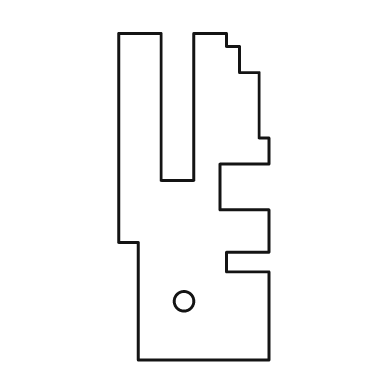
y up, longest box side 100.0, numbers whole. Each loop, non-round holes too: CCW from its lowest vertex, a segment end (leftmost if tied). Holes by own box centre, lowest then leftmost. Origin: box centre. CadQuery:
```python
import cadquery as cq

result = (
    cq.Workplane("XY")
    .moveTo(-17.0, -50.0)
    .lineTo(23.0, -50.0)
    .lineTo(23.0, -23.0)
    .lineTo(10.0, -23.0)
    .lineTo(10.0, -17.0)
    .lineTo(23.0, -17.0)
    .lineTo(23.0, -4.0)
    .lineTo(8.0, -4.0)
    .lineTo(8.0, 10.0)
    .lineTo(23.0, 10.0)
    .lineTo(23.0, 18.0)
    .lineTo(20.0, 18.0)
    .lineTo(20.0, 38.0)
    .lineTo(14.0, 38.0)
    .lineTo(14.0, 46.0)
    .lineTo(10.0, 46.0)
    .lineTo(10.0, 50.0)
    .lineTo(0.0, 50.0)
    .lineTo(0.0, 5.0)
    .lineTo(-10.0, 5.0)
    .lineTo(-10.0, 50.0)
    .lineTo(-23.0, 50.0)
    .lineTo(-23.0, -14.0)
    .lineTo(-17.0, -14.0)
    .close()
    .moveTo(-3.0, -32.0)
    .circle(3.0)
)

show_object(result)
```